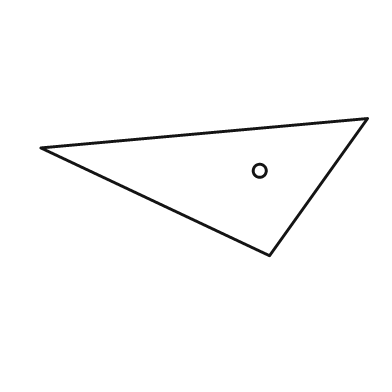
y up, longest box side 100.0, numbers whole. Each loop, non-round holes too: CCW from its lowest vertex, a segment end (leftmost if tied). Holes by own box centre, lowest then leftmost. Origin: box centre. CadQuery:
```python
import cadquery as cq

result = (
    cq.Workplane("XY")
    .moveTo(20.0, -21.0)
    .lineTo(50.0, 21.0)
    .lineTo(-50.0, 12.0)
    .close()
    .moveTo(17.0, 5.0)
    .circle(2.0)
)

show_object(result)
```